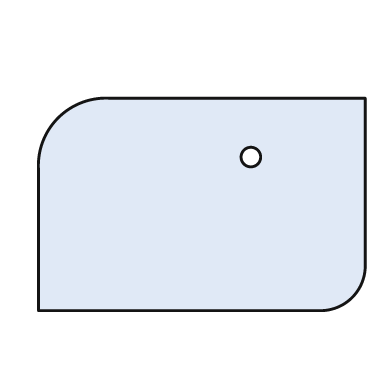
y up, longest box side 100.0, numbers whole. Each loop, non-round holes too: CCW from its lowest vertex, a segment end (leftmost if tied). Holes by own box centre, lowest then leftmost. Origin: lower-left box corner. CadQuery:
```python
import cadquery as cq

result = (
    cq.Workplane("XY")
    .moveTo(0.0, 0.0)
    .lineTo(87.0, 0.0)
    .threePointArc((96.0, 4.0), (100.0, 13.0))
    .lineTo(100.0, 65.0)
    .lineTo(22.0, 65.0)
    .threePointArc((6.0, 59.0), (0.0, 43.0))
    .close()
    .moveTo(65.0, 47.0)
    .circle(3.0)
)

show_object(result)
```